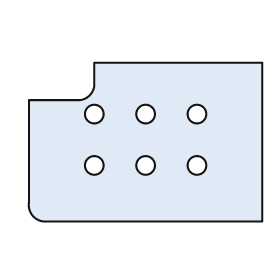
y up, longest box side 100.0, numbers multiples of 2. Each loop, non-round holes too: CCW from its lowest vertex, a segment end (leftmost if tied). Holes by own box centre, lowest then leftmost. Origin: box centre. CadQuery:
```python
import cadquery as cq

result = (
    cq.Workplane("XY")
    .moveTo(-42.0, -34.0)
    .lineTo(50.0, -34.0)
    .lineTo(50.0, 34.0)
    .lineTo(-22.0, 34.0)
    .lineTo(-22.0, 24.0)
    .threePointArc((-24.0, 20.0), (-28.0, 18.0))
    .lineTo(-50.0, 18.0)
    .lineTo(-50.0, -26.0)
    .threePointArc((-48.0, -32.0), (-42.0, -34.0))
    .close()
    .moveTo(-22.0, -10.0)
    .circle(4.0)
    .moveTo(0.0, -10.0)
    .circle(4.0)
    .moveTo(22.0, -10.0)
    .circle(4.0)
    .moveTo(-22.0, 12.0)
    .circle(4.0)
    .moveTo(0.0, 12.0)
    .circle(4.0)
    .moveTo(22.0, 12.0)
    .circle(4.0)
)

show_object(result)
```